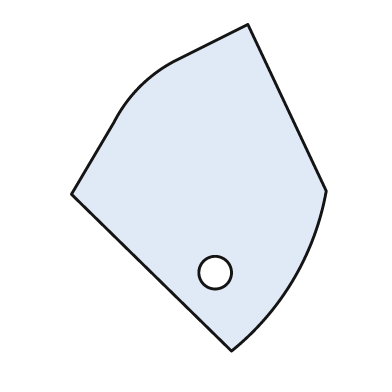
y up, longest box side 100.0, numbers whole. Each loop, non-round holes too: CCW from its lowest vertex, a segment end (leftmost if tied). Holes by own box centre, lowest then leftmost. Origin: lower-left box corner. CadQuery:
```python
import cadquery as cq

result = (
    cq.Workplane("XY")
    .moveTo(49.0, 0.0)
    .threePointArc((68.0, 22.0), (78.0, 49.0))
    .lineTo(54.0, 100.0)
    .lineTo(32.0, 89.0)
    .threePointArc((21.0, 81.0), (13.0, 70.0))
    .lineTo(0.0, 48.0)
    .close()
    .moveTo(44.0, 24.0)
    .circle(5.0)
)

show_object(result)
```